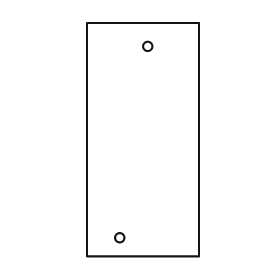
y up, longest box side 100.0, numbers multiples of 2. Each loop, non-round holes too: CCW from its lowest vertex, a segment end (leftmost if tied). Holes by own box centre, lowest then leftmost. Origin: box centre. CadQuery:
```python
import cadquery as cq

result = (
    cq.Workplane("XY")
    .moveTo(-24.0, -50.0)
    .lineTo(24.0, -50.0)
    .lineTo(24.0, 50.0)
    .lineTo(-24.0, 50.0)
    .close()
    .moveTo(-10.0, -42.0)
    .circle(2.0)
    .moveTo(2.0, 40.0)
    .circle(2.0)
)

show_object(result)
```